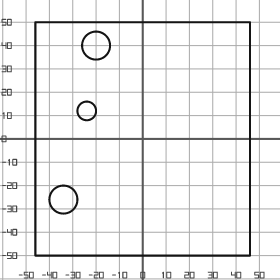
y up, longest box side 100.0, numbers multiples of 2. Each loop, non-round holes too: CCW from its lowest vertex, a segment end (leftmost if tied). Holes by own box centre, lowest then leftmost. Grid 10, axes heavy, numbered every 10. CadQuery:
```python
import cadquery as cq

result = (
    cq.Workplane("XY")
    .moveTo(-46.0, -50.0)
    .lineTo(46.0, -50.0)
    .lineTo(46.0, 50.0)
    .lineTo(-46.0, 50.0)
    .close()
    .moveTo(-34.0, -26.0)
    .circle(6.0)
    .moveTo(-24.0, 12.0)
    .circle(4.0)
    .moveTo(-20.0, 40.0)
    .circle(6.0)
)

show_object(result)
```